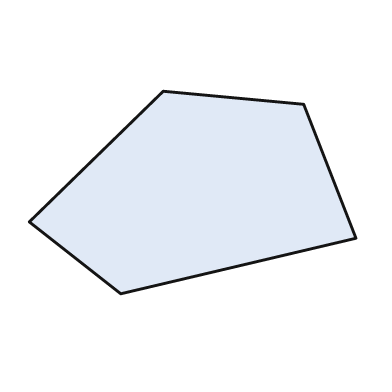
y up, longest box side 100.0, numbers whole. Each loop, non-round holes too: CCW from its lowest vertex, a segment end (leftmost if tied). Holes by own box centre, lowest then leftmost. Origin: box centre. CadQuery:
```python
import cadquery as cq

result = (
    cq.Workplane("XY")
    .moveTo(-22.0, -31.0)
    .lineTo(50.0, -14.0)
    .lineTo(34.0, 27.0)
    .lineTo(-9.0, 31.0)
    .lineTo(-50.0, -9.0)
    .close()
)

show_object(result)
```